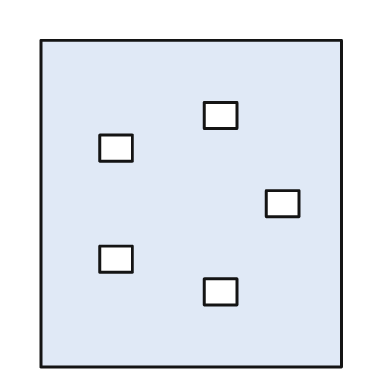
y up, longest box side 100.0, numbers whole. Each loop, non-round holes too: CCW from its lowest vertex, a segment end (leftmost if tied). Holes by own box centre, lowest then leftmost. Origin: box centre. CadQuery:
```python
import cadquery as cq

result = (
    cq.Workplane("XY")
    .moveTo(-46.0, -50.0)
    .lineTo(46.0, -50.0)
    .lineTo(46.0, 50.0)
    .lineTo(-46.0, 50.0)
    .close()
    .moveTo(4.0, -31.0)
    .lineTo(14.0, -31.0)
    .lineTo(14.0, -23.0)
    .lineTo(4.0, -23.0)
    .close()
    .moveTo(-28.0, -21.0)
    .lineTo(-18.0, -21.0)
    .lineTo(-18.0, -13.0)
    .lineTo(-28.0, -13.0)
    .close()
    .moveTo(23.0, -4.0)
    .lineTo(33.0, -4.0)
    .lineTo(33.0, 4.0)
    .lineTo(23.0, 4.0)
    .close()
    .moveTo(-28.0, 13.0)
    .lineTo(-18.0, 13.0)
    .lineTo(-18.0, 21.0)
    .lineTo(-28.0, 21.0)
    .close()
    .moveTo(4.0, 23.0)
    .lineTo(14.0, 23.0)
    .lineTo(14.0, 31.0)
    .lineTo(4.0, 31.0)
    .close()
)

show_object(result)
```